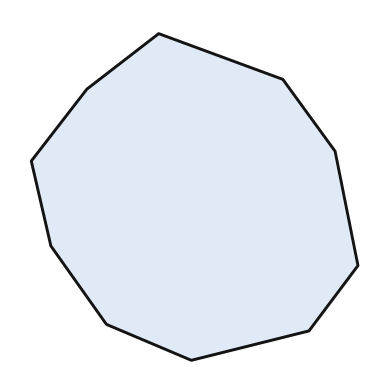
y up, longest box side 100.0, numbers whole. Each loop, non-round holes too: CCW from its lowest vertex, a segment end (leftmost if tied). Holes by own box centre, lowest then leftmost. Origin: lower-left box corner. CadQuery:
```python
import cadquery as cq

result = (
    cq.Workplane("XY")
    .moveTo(49.0, 0.0)
    .lineTo(85.0, 9.0)
    .lineTo(100.0, 29.0)
    .lineTo(93.0, 64.0)
    .lineTo(77.0, 86.0)
    .lineTo(39.0, 100.0)
    .lineTo(17.0, 83.0)
    .lineTo(0.0, 61.0)
    .lineTo(6.0, 35.0)
    .lineTo(23.0, 11.0)
    .close()
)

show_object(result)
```